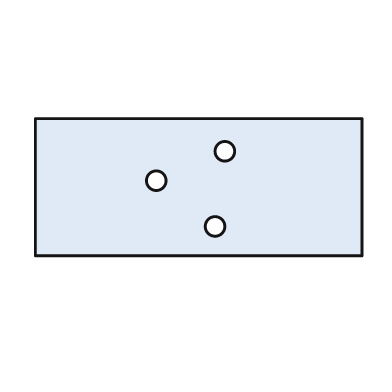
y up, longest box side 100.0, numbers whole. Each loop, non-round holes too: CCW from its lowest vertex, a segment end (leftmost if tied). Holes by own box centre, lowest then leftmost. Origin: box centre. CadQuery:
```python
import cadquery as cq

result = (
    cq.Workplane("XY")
    .moveTo(-50.0, -21.0)
    .lineTo(50.0, -21.0)
    .lineTo(50.0, 21.0)
    .lineTo(-50.0, 21.0)
    .close()
    .moveTo(5.0, -12.0)
    .circle(3.0)
    .moveTo(-13.0, 2.0)
    .circle(3.0)
    .moveTo(8.0, 11.0)
    .circle(3.0)
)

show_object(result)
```